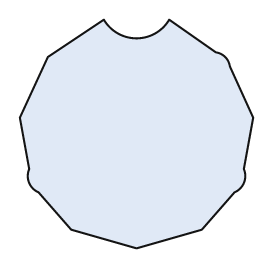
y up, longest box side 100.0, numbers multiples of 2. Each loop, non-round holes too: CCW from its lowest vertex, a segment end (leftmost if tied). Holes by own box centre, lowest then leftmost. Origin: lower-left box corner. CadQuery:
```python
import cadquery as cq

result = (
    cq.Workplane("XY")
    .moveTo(50.0, 0.0)
    .lineTo(78.0, 8.0)
    .lineTo(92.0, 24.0)
    .threePointArc((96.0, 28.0), (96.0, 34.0))
    .lineTo(100.0, 56.0)
    .lineTo(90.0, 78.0)
    .threePointArc((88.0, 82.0), (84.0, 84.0))
    .lineTo(64.0, 98.0)
    .threePointArc((50.0, 90.0), (36.0, 98.0))
    .lineTo(12.0, 82.0)
    .lineTo(0.0, 56.0)
    .lineTo(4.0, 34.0)
    .threePointArc((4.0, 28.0), (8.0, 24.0))
    .lineTo(22.0, 8.0)
    .close()
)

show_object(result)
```